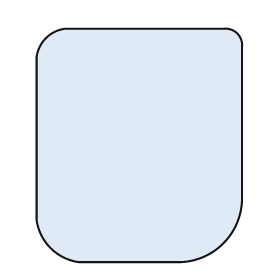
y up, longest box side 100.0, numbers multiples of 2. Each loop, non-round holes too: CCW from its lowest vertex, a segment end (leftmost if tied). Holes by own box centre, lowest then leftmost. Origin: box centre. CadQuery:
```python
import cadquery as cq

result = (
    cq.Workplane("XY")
    .moveTo(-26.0, -50.0)
    .lineTo(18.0, -50.0)
    .threePointArc((36.0, -42.0), (44.0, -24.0))
    .lineTo(44.0, 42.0)
    .threePointArc((42.0, 48.0), (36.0, 50.0))
    .lineTo(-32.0, 50.0)
    .threePointArc((-40.0, 46.0), (-44.0, 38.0))
    .lineTo(-44.0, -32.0)
    .threePointArc((-38.0, -44.0), (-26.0, -50.0))
    .close()
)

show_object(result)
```